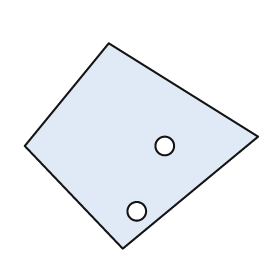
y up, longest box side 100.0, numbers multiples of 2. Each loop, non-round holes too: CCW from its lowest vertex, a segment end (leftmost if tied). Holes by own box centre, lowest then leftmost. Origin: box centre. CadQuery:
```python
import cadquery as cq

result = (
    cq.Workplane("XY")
    .moveTo(-8.0, -44.0)
    .lineTo(50.0, 4.0)
    .lineTo(-14.0, 44.0)
    .lineTo(-50.0, 0.0)
    .close()
    .moveTo(-2.0, -28.0)
    .circle(4.0)
    .moveTo(10.0, 0.0)
    .circle(4.0)
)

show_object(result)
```